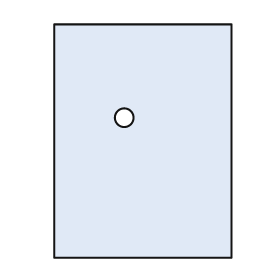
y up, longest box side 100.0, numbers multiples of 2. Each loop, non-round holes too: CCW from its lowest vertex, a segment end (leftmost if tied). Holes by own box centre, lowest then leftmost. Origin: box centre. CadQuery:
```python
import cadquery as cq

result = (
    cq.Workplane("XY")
    .moveTo(-38.0, -50.0)
    .lineTo(38.0, -50.0)
    .lineTo(38.0, 50.0)
    .lineTo(-38.0, 50.0)
    .close()
    .moveTo(-8.0, 10.0)
    .circle(4.0)
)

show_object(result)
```